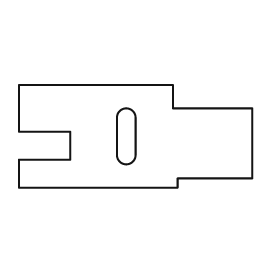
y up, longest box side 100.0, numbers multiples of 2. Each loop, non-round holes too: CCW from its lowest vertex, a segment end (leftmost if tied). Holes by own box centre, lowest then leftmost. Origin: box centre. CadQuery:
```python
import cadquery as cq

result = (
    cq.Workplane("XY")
    .moveTo(-50.0, -22.0)
    .lineTo(18.0, -22.0)
    .lineTo(18.0, -18.0)
    .lineTo(50.0, -18.0)
    .lineTo(50.0, 12.0)
    .lineTo(16.0, 12.0)
    .lineTo(16.0, 22.0)
    .lineTo(-50.0, 22.0)
    .lineTo(-50.0, 2.0)
    .lineTo(-28.0, 2.0)
    .lineTo(-28.0, -10.0)
    .lineTo(-50.0, -10.0)
    .close()
    .moveTo(-8.0, -8.0)
    .threePointArc((-4.0, -12.0), (0.0, -8.0))
    .lineTo(0.0, 8.0)
    .threePointArc((-4.0, 12.0), (-8.0, 8.0))
    .close()
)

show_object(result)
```